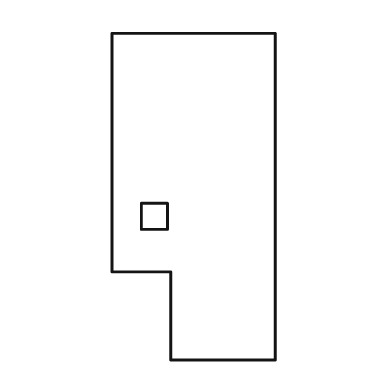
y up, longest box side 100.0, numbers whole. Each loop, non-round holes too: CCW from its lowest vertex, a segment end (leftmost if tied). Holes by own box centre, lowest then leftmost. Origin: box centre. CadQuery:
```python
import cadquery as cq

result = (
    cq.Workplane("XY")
    .moveTo(-7.0, -50.0)
    .lineTo(25.0, -50.0)
    .lineTo(25.0, 50.0)
    .lineTo(-25.0, 50.0)
    .lineTo(-25.0, -23.0)
    .lineTo(-7.0, -23.0)
    .close()
    .moveTo(-16.0, -10.0)
    .lineTo(-8.0, -10.0)
    .lineTo(-8.0, -2.0)
    .lineTo(-16.0, -2.0)
    .close()
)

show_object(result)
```